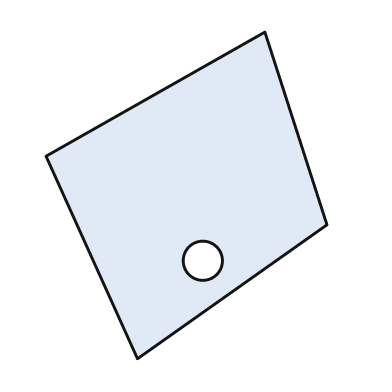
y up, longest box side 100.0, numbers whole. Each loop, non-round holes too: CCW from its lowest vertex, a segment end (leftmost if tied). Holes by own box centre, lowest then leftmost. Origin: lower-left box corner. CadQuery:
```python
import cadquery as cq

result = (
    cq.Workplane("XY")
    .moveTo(28.0, 0.0)
    .lineTo(86.0, 41.0)
    .lineTo(67.0, 100.0)
    .lineTo(0.0, 62.0)
    .close()
    .moveTo(48.0, 30.0)
    .circle(6.0)
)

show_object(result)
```